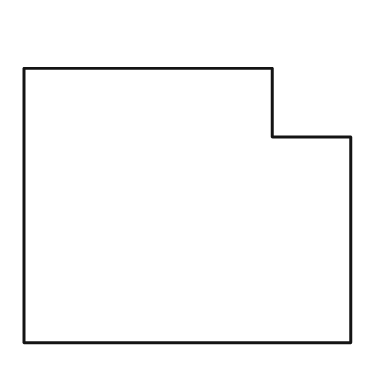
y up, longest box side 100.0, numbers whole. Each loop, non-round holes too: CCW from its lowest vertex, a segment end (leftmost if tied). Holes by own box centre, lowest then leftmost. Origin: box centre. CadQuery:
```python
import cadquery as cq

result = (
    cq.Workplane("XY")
    .moveTo(-50.0, -42.0)
    .lineTo(50.0, -42.0)
    .lineTo(50.0, 21.0)
    .lineTo(26.0, 21.0)
    .lineTo(26.0, 42.0)
    .lineTo(-50.0, 42.0)
    .close()
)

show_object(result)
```